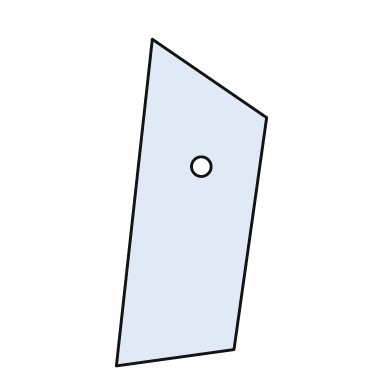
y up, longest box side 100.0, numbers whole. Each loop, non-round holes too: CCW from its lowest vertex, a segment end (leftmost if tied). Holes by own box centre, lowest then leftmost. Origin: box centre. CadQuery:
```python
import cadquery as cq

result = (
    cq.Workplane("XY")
    .moveTo(-23.0, -50.0)
    .lineTo(13.0, -45.0)
    .lineTo(23.0, 26.0)
    .lineTo(-12.0, 50.0)
    .close()
    .moveTo(3.0, 11.0)
    .circle(3.0)
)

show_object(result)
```